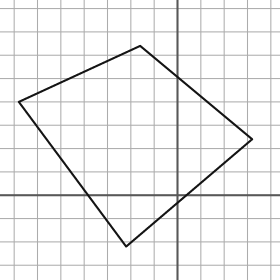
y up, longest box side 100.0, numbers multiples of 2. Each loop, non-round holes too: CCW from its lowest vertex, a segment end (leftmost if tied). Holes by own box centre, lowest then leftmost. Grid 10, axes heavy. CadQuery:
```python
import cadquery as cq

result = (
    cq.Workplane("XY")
    .moveTo(-22.0, -22.0)
    .lineTo(32.0, 24.0)
    .lineTo(-16.0, 64.0)
    .lineTo(-68.0, 40.0)
    .close()
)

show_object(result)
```